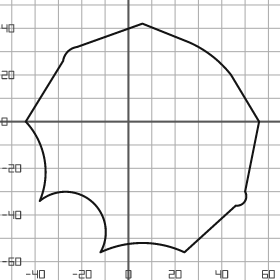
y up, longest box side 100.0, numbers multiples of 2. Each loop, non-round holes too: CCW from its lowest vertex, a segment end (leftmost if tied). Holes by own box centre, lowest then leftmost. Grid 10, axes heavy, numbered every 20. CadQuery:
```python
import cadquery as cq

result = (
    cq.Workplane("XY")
    .moveTo(-12.0, -56.0)
    .threePointArc((6.0, -52.0), (24.0, -56.0))
    .lineTo(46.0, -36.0)
    .threePointArc((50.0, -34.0), (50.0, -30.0))
    .lineTo(56.0, 0.0)
    .lineTo(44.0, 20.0)
    .threePointArc((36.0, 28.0), (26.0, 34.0))
    .lineTo(6.0, 42.0)
    .lineTo(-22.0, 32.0)
    .threePointArc((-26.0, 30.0), (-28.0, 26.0))
    .lineTo(-44.0, 0.0)
    .threePointArc((-36.0, -16.0), (-38.0, -34.0))
    .threePointArc((-16.0, -34.0), (-12.0, -56.0))
    .close()
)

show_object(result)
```